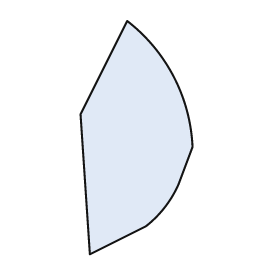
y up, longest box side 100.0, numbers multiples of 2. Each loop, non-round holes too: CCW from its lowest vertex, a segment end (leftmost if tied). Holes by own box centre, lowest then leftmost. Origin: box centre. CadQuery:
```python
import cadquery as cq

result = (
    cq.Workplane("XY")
    .moveTo(-20.0, -50.0)
    .lineTo(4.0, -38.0)
    .threePointArc((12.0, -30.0), (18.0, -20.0))
    .lineTo(24.0, -4.0)
    .threePointArc((16.0, 26.0), (-4.0, 50.0))
    .lineTo(-24.0, 10.0)
    .close()
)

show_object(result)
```